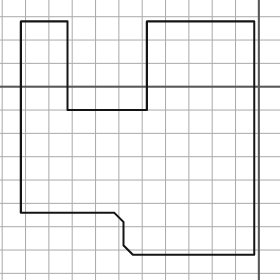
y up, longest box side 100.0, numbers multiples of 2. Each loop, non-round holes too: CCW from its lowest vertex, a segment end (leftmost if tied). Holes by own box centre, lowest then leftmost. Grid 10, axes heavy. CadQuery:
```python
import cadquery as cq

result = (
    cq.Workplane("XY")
    .moveTo(-54.0, -72.0)
    .lineTo(-2.0, -72.0)
    .lineTo(-2.0, 28.0)
    .lineTo(-48.0, 28.0)
    .lineTo(-48.0, -10.0)
    .lineTo(-82.0, -10.0)
    .lineTo(-82.0, 28.0)
    .lineTo(-102.0, 28.0)
    .lineTo(-102.0, -54.0)
    .lineTo(-62.0, -54.0)
    .lineTo(-58.0, -58.0)
    .lineTo(-58.0, -68.0)
    .close()
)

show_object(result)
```